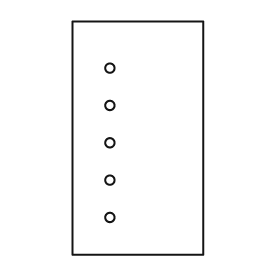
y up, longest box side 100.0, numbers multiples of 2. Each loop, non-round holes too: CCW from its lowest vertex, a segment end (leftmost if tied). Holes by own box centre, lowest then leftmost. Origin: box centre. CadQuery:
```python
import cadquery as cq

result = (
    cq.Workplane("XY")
    .moveTo(-28.0, -50.0)
    .lineTo(28.0, -50.0)
    .lineTo(28.0, 50.0)
    .lineTo(-28.0, 50.0)
    .close()
    .moveTo(-12.0, -34.0)
    .circle(2.0)
    .moveTo(-12.0, -18.0)
    .circle(2.0)
    .moveTo(-12.0, -2.0)
    .circle(2.0)
    .moveTo(-12.0, 14.0)
    .circle(2.0)
    .moveTo(-12.0, 30.0)
    .circle(2.0)
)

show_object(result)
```